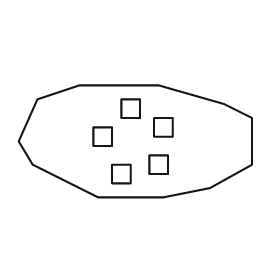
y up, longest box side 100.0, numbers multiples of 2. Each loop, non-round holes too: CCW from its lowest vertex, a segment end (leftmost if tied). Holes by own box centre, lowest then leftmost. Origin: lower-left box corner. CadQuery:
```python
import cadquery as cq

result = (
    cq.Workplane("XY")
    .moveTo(34.0, 0.0)
    .lineTo(62.0, 0.0)
    .lineTo(82.0, 4.0)
    .lineTo(100.0, 14.0)
    .lineTo(100.0, 34.0)
    .lineTo(88.0, 40.0)
    .lineTo(60.0, 48.0)
    .lineTo(26.0, 48.0)
    .lineTo(8.0, 42.0)
    .lineTo(0.0, 24.0)
    .lineTo(6.0, 14.0)
    .close()
    .moveTo(40.0, 6.0)
    .lineTo(48.0, 6.0)
    .lineTo(48.0, 14.0)
    .lineTo(40.0, 14.0)
    .close()
    .moveTo(56.0, 10.0)
    .lineTo(64.0, 10.0)
    .lineTo(64.0, 18.0)
    .lineTo(56.0, 18.0)
    .close()
    .moveTo(32.0, 22.0)
    .lineTo(40.0, 22.0)
    .lineTo(40.0, 30.0)
    .lineTo(32.0, 30.0)
    .close()
    .moveTo(58.0, 26.0)
    .lineTo(66.0, 26.0)
    .lineTo(66.0, 34.0)
    .lineTo(58.0, 34.0)
    .close()
    .moveTo(44.0, 34.0)
    .lineTo(52.0, 34.0)
    .lineTo(52.0, 42.0)
    .lineTo(44.0, 42.0)
    .close()
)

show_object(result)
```